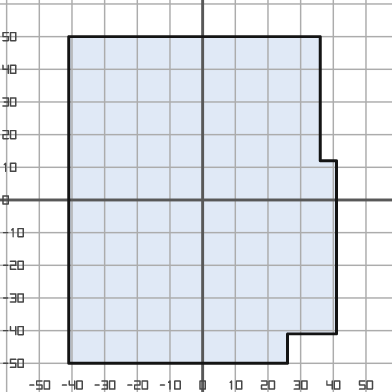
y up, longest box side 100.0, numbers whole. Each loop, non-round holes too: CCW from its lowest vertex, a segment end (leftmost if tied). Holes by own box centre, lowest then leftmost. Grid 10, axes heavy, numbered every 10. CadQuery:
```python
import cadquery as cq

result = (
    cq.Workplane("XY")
    .moveTo(-41.0, -50.0)
    .lineTo(26.0, -50.0)
    .lineTo(26.0, -41.0)
    .lineTo(41.0, -41.0)
    .lineTo(41.0, 12.0)
    .lineTo(36.0, 12.0)
    .lineTo(36.0, 50.0)
    .lineTo(-41.0, 50.0)
    .close()
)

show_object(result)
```